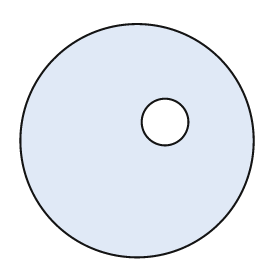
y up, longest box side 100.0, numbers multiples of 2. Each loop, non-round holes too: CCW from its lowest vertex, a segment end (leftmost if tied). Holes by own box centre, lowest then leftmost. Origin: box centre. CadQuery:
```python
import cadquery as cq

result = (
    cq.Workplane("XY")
    .moveTo(0.0, 0.0)
    .circle(50.0)
    .moveTo(12.0, 8.0)
    .circle(10.0)
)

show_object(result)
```